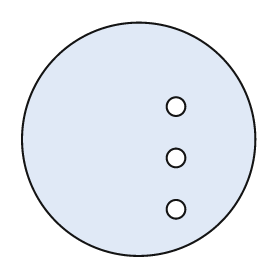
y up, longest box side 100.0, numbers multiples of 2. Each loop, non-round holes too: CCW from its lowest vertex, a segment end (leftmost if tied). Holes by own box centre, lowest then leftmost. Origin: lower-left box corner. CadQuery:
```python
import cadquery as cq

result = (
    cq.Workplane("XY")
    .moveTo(50.0, 50.0)
    .circle(50.0)
    .moveTo(66.0, 20.0)
    .circle(4.0)
    .moveTo(66.0, 42.0)
    .circle(4.0)
    .moveTo(66.0, 64.0)
    .circle(4.0)
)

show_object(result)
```